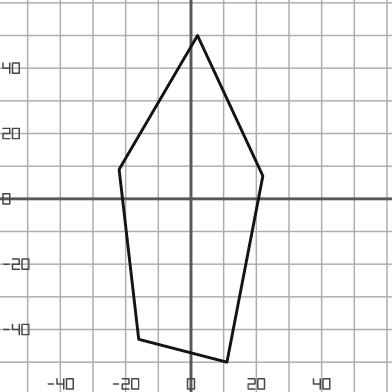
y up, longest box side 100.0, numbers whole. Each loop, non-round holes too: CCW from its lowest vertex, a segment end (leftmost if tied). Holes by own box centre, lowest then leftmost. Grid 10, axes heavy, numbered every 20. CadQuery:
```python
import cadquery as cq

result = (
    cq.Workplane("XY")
    .moveTo(11.0, -50.0)
    .lineTo(22.0, 7.0)
    .lineTo(2.0, 50.0)
    .lineTo(-22.0, 9.0)
    .lineTo(-16.0, -43.0)
    .close()
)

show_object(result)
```